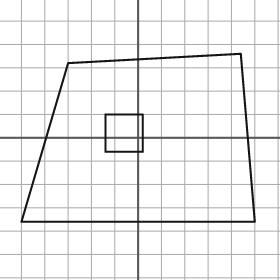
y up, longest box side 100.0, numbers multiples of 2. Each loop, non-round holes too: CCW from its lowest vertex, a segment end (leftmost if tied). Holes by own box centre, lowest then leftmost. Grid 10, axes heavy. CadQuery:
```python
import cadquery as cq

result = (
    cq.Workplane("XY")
    .moveTo(-50.0, -36.0)
    .lineTo(50.0, -36.0)
    .lineTo(44.0, 36.0)
    .lineTo(-30.0, 32.0)
    .close()
    .moveTo(-14.0, -6.0)
    .lineTo(2.0, -6.0)
    .lineTo(2.0, 10.0)
    .lineTo(-14.0, 10.0)
    .close()
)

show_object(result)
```